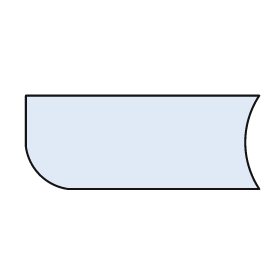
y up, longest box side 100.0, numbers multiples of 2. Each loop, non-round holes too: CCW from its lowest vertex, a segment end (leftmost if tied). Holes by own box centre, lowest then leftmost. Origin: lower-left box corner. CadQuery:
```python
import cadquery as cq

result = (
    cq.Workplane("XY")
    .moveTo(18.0, 0.0)
    .lineTo(100.0, 0.0)
    .threePointArc((94.0, 20.0), (100.0, 40.0))
    .lineTo(0.0, 40.0)
    .lineTo(0.0, 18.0)
    .threePointArc((6.0, 6.0), (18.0, 0.0))
    .close()
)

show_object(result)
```